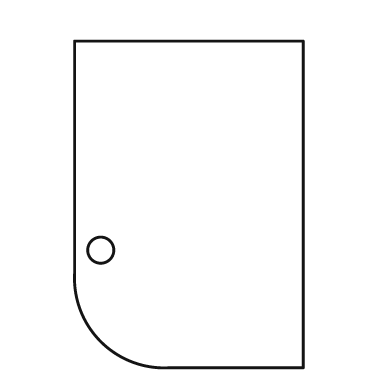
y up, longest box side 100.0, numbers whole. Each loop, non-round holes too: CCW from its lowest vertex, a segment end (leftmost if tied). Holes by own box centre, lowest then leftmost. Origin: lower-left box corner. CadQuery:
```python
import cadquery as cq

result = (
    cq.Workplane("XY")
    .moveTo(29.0, 0.0)
    .lineTo(70.0, 0.0)
    .lineTo(70.0, 100.0)
    .lineTo(0.0, 100.0)
    .lineTo(0.0, 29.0)
    .threePointArc((8.0, 8.0), (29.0, 0.0))
    .close()
    .moveTo(8.0, 36.0)
    .circle(4.0)
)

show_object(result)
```